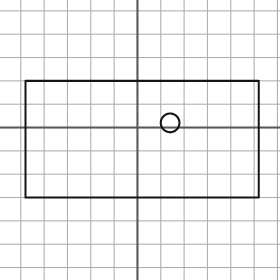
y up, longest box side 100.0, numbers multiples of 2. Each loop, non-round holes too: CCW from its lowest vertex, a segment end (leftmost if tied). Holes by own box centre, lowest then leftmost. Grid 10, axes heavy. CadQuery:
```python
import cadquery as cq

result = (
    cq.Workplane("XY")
    .moveTo(-48.0, -30.0)
    .lineTo(52.0, -30.0)
    .lineTo(52.0, 20.0)
    .lineTo(-48.0, 20.0)
    .close()
    .moveTo(14.0, 2.0)
    .circle(4.0)
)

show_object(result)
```